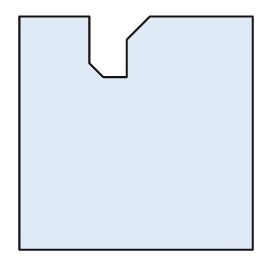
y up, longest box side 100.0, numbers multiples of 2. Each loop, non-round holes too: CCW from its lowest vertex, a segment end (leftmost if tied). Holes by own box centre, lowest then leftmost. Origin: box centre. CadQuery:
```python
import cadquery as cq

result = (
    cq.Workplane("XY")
    .moveTo(-50.0, -50.0)
    .lineTo(50.0, -50.0)
    .lineTo(50.0, 50.0)
    .lineTo(6.0, 50.0)
    .lineTo(-4.0, 40.0)
    .lineTo(-4.0, 24.0)
    .lineTo(-14.0, 24.0)
    .lineTo(-20.0, 30.0)
    .lineTo(-20.0, 50.0)
    .lineTo(-50.0, 50.0)
    .close()
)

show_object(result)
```